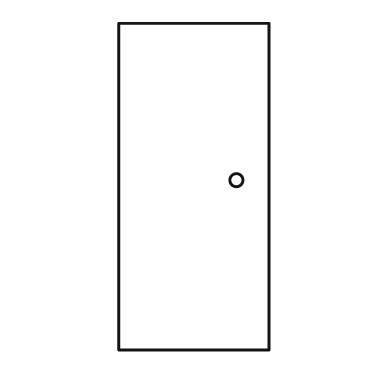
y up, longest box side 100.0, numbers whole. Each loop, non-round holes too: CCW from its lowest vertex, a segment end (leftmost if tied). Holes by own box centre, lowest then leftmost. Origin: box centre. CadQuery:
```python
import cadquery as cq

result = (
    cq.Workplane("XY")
    .moveTo(-23.0, -50.0)
    .lineTo(23.0, -50.0)
    .lineTo(23.0, 50.0)
    .lineTo(-23.0, 50.0)
    .close()
    .moveTo(13.0, 2.0)
    .circle(2.0)
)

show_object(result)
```